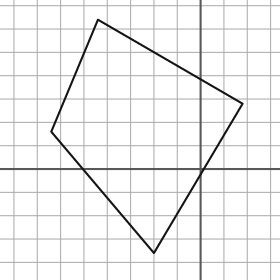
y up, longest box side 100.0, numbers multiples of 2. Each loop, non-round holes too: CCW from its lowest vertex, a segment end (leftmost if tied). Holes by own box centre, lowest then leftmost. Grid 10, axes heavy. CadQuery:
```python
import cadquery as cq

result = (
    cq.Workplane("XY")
    .moveTo(-20.0, -36.0)
    .lineTo(18.0, 28.0)
    .lineTo(-44.0, 64.0)
    .lineTo(-64.0, 16.0)
    .close()
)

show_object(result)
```